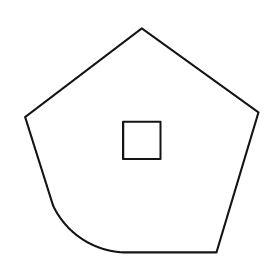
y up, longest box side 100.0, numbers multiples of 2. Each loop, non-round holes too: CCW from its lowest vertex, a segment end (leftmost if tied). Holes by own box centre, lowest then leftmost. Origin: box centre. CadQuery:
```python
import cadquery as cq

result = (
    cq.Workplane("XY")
    .moveTo(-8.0, -48.0)
    .lineTo(32.0, -48.0)
    .lineTo(50.0, 12.0)
    .lineTo(0.0, 48.0)
    .lineTo(-50.0, 10.0)
    .lineTo(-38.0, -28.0)
    .threePointArc((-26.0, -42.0), (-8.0, -48.0))
    .close()
    .moveTo(-8.0, -8.0)
    .lineTo(8.0, -8.0)
    .lineTo(8.0, 8.0)
    .lineTo(-8.0, 8.0)
    .close()
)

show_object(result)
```